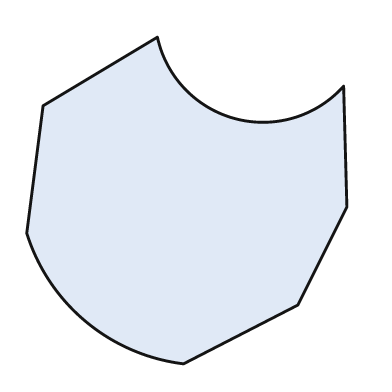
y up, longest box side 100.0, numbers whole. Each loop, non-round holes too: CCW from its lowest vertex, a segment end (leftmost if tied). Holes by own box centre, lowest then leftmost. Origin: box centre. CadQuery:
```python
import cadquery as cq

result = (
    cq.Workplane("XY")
    .moveTo(-1.0, -50.0)
    .lineTo(34.0, -32.0)
    .lineTo(49.0, -2.0)
    .lineTo(48.0, 35.0)
    .threePointArc((15.0, 25.0), (-9.0, 50.0))
    .lineTo(-44.0, 29.0)
    .lineTo(-49.0, -10.0)
    .threePointArc((-31.0, -37.0), (-1.0, -50.0))
    .close()
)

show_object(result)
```